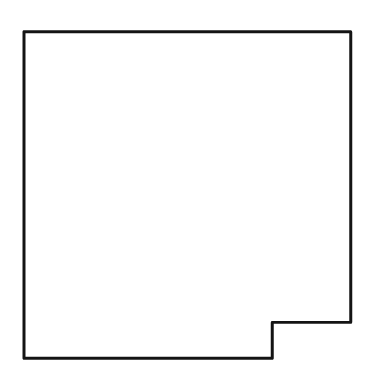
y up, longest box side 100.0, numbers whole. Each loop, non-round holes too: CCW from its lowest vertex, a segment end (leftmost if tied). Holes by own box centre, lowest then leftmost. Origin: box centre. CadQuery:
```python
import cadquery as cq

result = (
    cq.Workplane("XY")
    .moveTo(-50.0, -50.0)
    .lineTo(26.0, -50.0)
    .lineTo(26.0, -39.0)
    .lineTo(50.0, -39.0)
    .lineTo(50.0, 50.0)
    .lineTo(-50.0, 50.0)
    .close()
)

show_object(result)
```